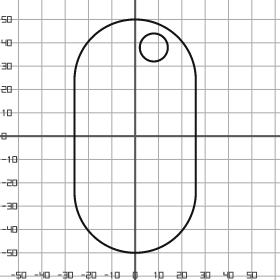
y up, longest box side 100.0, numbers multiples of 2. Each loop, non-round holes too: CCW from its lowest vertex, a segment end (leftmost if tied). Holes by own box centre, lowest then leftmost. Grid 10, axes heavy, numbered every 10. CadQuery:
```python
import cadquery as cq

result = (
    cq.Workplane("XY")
    .moveTo(-26.0, -24.0)
    .threePointArc((0.0, -50.0), (26.0, -24.0))
    .lineTo(26.0, 24.0)
    .threePointArc((0.0, 50.0), (-26.0, 24.0))
    .close()
    .moveTo(8.0, 38.0)
    .circle(6.0)
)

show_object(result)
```